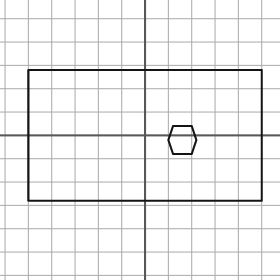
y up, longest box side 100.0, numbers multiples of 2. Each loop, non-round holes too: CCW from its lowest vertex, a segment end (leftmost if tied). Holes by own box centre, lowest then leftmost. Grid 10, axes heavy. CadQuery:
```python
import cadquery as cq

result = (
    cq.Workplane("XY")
    .moveTo(-50.0, -28.0)
    .lineTo(50.0, -28.0)
    .lineTo(50.0, 28.0)
    .lineTo(-50.0, 28.0)
    .close()
    .moveTo(12.0, -8.0)
    .lineTo(20.0, -8.0)
    .lineTo(22.0, -2.0)
    .lineTo(20.0, 4.0)
    .lineTo(12.0, 4.0)
    .lineTo(10.0, -2.0)
    .close()
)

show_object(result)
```